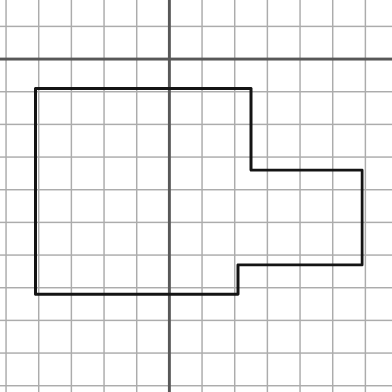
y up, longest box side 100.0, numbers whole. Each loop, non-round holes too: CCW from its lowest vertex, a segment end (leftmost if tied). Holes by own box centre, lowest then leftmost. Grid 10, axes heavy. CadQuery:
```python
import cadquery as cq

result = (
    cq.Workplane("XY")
    .moveTo(-41.0, -72.0)
    .lineTo(21.0, -72.0)
    .lineTo(21.0, -63.0)
    .lineTo(59.0, -63.0)
    .lineTo(59.0, -34.0)
    .lineTo(25.0, -34.0)
    .lineTo(25.0, -9.0)
    .lineTo(-41.0, -9.0)
    .close()
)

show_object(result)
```